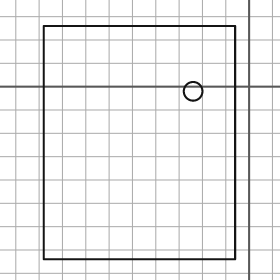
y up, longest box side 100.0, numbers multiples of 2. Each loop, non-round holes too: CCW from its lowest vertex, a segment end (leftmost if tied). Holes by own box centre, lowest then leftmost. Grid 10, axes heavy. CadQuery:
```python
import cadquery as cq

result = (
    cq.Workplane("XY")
    .moveTo(-88.0, -74.0)
    .lineTo(-6.0, -74.0)
    .lineTo(-6.0, 26.0)
    .lineTo(-88.0, 26.0)
    .close()
    .moveTo(-24.0, -2.0)
    .circle(4.0)
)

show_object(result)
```